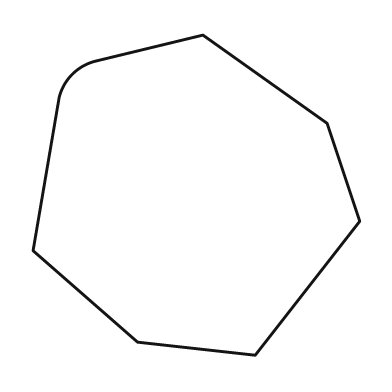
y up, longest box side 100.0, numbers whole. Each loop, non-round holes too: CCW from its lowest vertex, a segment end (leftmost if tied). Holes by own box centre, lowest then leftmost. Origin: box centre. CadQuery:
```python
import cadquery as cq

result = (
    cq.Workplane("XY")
    .moveTo(18.0, -49.0)
    .lineTo(50.0, -8.0)
    .lineTo(40.0, 22.0)
    .lineTo(2.0, 49.0)
    .lineTo(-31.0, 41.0)
    .threePointArc((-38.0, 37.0), (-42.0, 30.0))
    .lineTo(-50.0, -17.0)
    .lineTo(-18.0, -45.0)
    .close()
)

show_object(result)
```